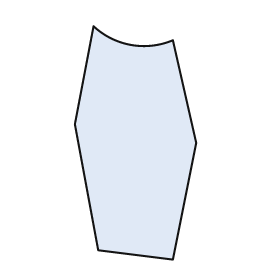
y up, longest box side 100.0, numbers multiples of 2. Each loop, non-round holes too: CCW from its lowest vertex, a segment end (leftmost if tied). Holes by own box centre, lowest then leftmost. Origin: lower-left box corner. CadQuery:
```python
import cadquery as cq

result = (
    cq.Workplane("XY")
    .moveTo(42.0, 0.0)
    .lineTo(52.0, 50.0)
    .lineTo(42.0, 94.0)
    .threePointArc((24.0, 92.0), (8.0, 100.0))
    .lineTo(0.0, 58.0)
    .lineTo(10.0, 4.0)
    .close()
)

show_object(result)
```